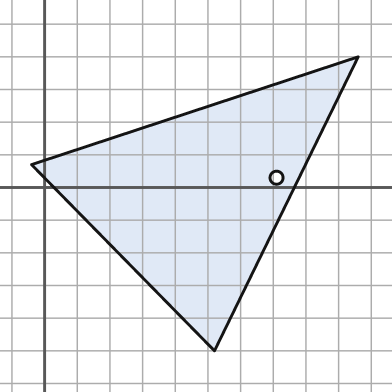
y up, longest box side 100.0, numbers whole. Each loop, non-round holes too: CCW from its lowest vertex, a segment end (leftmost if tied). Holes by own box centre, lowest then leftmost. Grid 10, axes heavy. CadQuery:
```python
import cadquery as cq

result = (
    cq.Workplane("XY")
    .moveTo(52.0, -50.0)
    .lineTo(96.0, 40.0)
    .lineTo(-4.0, 7.0)
    .close()
    .moveTo(71.0, 3.0)
    .circle(2.0)
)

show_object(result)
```